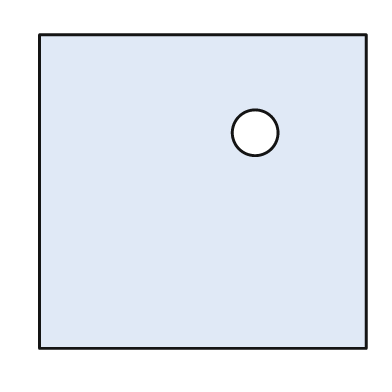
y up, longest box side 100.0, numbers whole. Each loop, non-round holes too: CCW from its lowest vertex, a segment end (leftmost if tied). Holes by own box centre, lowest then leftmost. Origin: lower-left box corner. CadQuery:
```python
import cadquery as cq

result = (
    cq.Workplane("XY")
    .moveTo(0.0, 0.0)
    .lineTo(100.0, 0.0)
    .lineTo(100.0, 96.0)
    .lineTo(0.0, 96.0)
    .close()
    .moveTo(66.0, 66.0)
    .circle(7.0)
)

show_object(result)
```